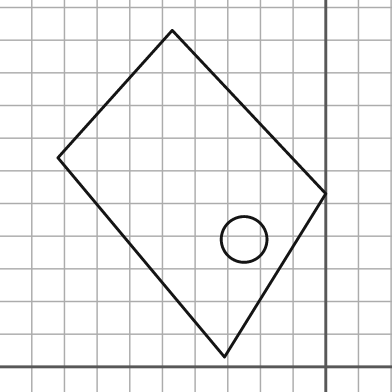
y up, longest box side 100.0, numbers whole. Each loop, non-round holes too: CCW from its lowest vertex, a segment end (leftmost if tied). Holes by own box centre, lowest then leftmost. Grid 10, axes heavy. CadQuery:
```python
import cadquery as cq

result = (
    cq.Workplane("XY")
    .moveTo(-31.0, 3.0)
    .lineTo(0.0, 53.0)
    .lineTo(-47.0, 103.0)
    .lineTo(-82.0, 64.0)
    .close()
    .moveTo(-25.0, 39.0)
    .circle(7.0)
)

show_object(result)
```